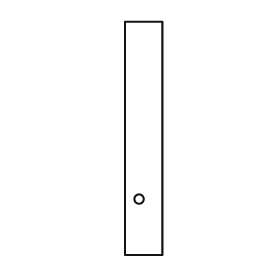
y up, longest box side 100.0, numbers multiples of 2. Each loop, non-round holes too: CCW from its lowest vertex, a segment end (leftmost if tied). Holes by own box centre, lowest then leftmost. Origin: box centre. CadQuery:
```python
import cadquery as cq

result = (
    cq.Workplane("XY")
    .moveTo(-8.0, -50.0)
    .lineTo(8.0, -50.0)
    .lineTo(8.0, 50.0)
    .lineTo(-8.0, 50.0)
    .close()
    .moveTo(-2.0, -26.0)
    .circle(2.0)
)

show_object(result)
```